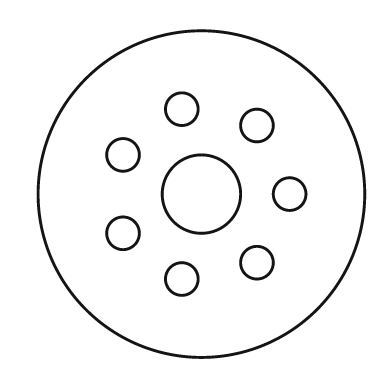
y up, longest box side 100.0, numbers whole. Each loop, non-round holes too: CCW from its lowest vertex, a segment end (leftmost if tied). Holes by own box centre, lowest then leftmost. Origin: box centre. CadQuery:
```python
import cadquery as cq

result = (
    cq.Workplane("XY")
    .moveTo(0.0, 0.0)
    .circle(50.0)
    .moveTo(-6.0, -26.0)
    .circle(5.0)
    .moveTo(17.0, -21.0)
    .circle(5.0)
    .moveTo(-24.0, -12.0)
    .circle(5.0)
    .moveTo(0.0, 0.0)
    .circle(12.0)
    .moveTo(27.0, 0.0)
    .circle(5.0)
    .moveTo(-24.0, 12.0)
    .circle(5.0)
    .moveTo(17.0, 21.0)
    .circle(5.0)
    .moveTo(-6.0, 26.0)
    .circle(5.0)
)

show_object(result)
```